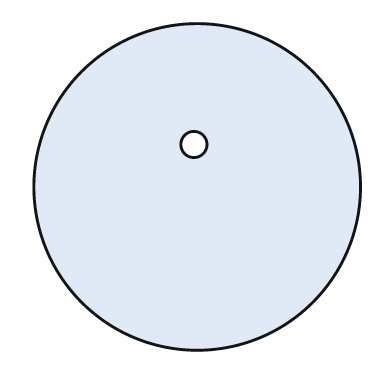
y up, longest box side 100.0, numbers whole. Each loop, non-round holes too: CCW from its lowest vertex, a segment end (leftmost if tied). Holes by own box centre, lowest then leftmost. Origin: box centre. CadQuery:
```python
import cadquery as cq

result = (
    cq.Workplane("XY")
    .moveTo(0.0, 0.0)
    .circle(50.0)
    .moveTo(-1.0, 13.0)
    .circle(4.0)
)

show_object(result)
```